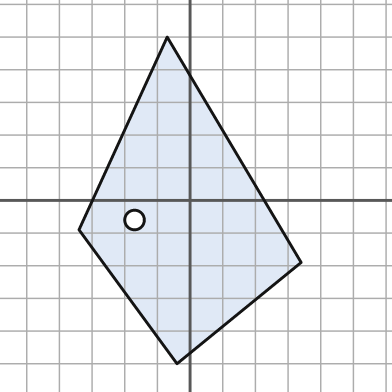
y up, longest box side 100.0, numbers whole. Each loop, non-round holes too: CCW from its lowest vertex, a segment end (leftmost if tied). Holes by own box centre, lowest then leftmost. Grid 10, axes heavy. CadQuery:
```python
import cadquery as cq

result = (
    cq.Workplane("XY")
    .moveTo(-4.0, -50.0)
    .lineTo(34.0, -19.0)
    .lineTo(-7.0, 50.0)
    .lineTo(-34.0, -9.0)
    .close()
    .moveTo(-17.0, -6.0)
    .circle(3.0)
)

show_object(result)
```